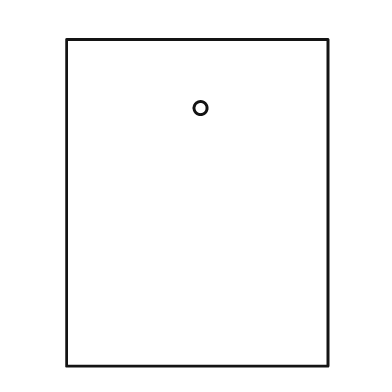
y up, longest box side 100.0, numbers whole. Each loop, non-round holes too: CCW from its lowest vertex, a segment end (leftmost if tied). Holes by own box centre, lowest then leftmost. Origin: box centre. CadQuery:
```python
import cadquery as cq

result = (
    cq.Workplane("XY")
    .moveTo(-40.0, -50.0)
    .lineTo(40.0, -50.0)
    .lineTo(40.0, 50.0)
    .lineTo(-40.0, 50.0)
    .close()
    .moveTo(1.0, 29.0)
    .circle(2.0)
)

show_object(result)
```